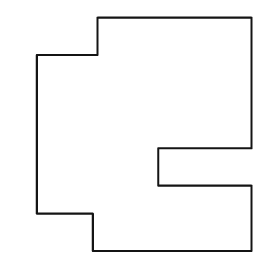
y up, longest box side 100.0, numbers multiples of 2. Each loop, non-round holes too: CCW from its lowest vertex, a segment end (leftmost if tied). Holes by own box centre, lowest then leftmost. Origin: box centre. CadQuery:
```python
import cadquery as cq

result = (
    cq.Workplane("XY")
    .moveTo(-22.0, -50.0)
    .lineTo(46.0, -50.0)
    .lineTo(46.0, -22.0)
    .lineTo(6.0, -22.0)
    .lineTo(6.0, -6.0)
    .lineTo(46.0, -6.0)
    .lineTo(46.0, 50.0)
    .lineTo(-20.0, 50.0)
    .lineTo(-20.0, 34.0)
    .lineTo(-46.0, 34.0)
    .lineTo(-46.0, -34.0)
    .lineTo(-22.0, -34.0)
    .close()
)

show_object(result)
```